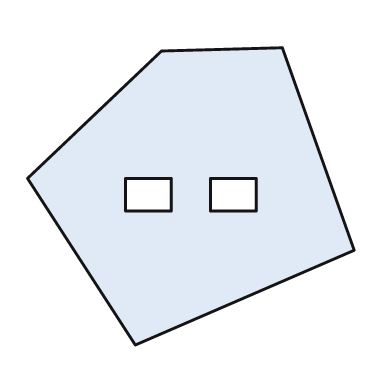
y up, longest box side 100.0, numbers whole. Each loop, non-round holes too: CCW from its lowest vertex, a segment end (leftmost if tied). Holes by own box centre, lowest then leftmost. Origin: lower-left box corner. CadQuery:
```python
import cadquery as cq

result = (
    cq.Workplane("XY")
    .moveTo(33.0, 0.0)
    .lineTo(100.0, 29.0)
    .lineTo(78.0, 91.0)
    .lineTo(41.0, 90.0)
    .lineTo(0.0, 51.0)
    .close()
    .moveTo(30.0, 41.0)
    .lineTo(44.0, 41.0)
    .lineTo(44.0, 51.0)
    .lineTo(30.0, 51.0)
    .close()
    .moveTo(56.0, 41.0)
    .lineTo(70.0, 41.0)
    .lineTo(70.0, 51.0)
    .lineTo(56.0, 51.0)
    .close()
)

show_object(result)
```